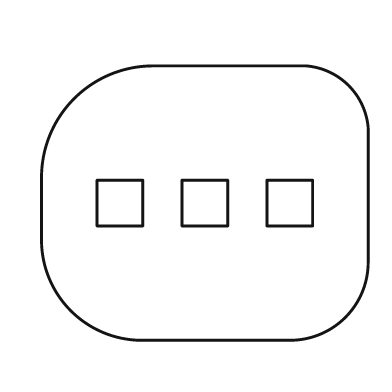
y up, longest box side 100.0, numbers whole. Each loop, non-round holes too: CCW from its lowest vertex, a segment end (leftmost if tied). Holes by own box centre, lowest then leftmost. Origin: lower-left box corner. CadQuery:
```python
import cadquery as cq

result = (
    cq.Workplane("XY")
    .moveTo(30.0, 0.0)
    .lineTo(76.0, 0.0)
    .threePointArc((93.0, 7.0), (100.0, 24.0))
    .lineTo(100.0, 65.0)
    .threePointArc((94.0, 78.0), (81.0, 84.0))
    .lineTo(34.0, 84.0)
    .threePointArc((10.0, 74.0), (0.0, 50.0))
    .lineTo(0.0, 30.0)
    .threePointArc((9.0, 9.0), (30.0, 0.0))
    .close()
    .moveTo(17.0, 35.0)
    .lineTo(31.0, 35.0)
    .lineTo(31.0, 49.0)
    .lineTo(17.0, 49.0)
    .close()
    .moveTo(43.0, 35.0)
    .lineTo(57.0, 35.0)
    .lineTo(57.0, 49.0)
    .lineTo(43.0, 49.0)
    .close()
    .moveTo(69.0, 35.0)
    .lineTo(83.0, 35.0)
    .lineTo(83.0, 49.0)
    .lineTo(69.0, 49.0)
    .close()
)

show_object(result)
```